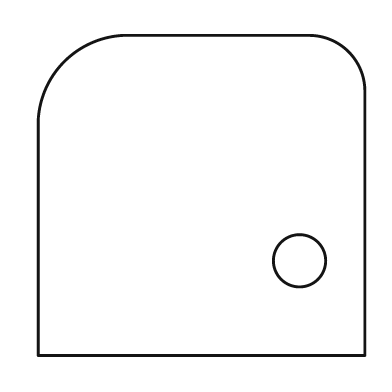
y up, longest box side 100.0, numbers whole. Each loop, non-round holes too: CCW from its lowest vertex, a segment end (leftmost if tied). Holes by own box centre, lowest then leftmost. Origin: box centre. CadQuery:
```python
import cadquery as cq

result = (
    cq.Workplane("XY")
    .moveTo(-50.0, -49.0)
    .lineTo(50.0, -49.0)
    .lineTo(50.0, 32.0)
    .threePointArc((45.0, 44.0), (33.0, 49.0))
    .lineTo(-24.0, 49.0)
    .threePointArc((-42.0, 41.0), (-50.0, 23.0))
    .close()
    .moveTo(30.0, -20.0)
    .circle(8.0)
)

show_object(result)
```